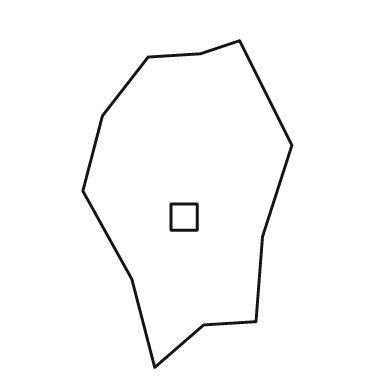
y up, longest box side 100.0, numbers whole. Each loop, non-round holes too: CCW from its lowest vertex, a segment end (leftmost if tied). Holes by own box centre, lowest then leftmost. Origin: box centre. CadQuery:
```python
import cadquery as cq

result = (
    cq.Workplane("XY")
    .moveTo(-10.0, -50.0)
    .lineTo(5.0, -37.0)
    .lineTo(21.0, -36.0)
    .lineTo(23.0, -10.0)
    .lineTo(32.0, 18.0)
    .lineTo(16.0, 50.0)
    .lineTo(4.0, 46.0)
    .lineTo(-12.0, 45.0)
    .lineTo(-26.0, 27.0)
    .lineTo(-32.0, 4.0)
    .lineTo(-17.0, -23.0)
    .close()
    .moveTo(-5.0, -8.0)
    .lineTo(3.0, -8.0)
    .lineTo(3.0, 0.0)
    .lineTo(-5.0, 0.0)
    .close()
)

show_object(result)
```